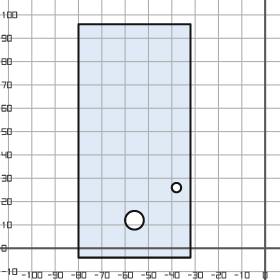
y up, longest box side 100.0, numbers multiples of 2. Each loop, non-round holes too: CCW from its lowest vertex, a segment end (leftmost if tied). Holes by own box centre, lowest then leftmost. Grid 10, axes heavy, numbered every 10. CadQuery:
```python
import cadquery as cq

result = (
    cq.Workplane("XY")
    .moveTo(-80.0, -4.0)
    .lineTo(-32.0, -4.0)
    .lineTo(-32.0, 96.0)
    .lineTo(-80.0, 96.0)
    .close()
    .moveTo(-56.0, 12.0)
    .circle(4.0)
    .moveTo(-38.0, 26.0)
    .circle(2.0)
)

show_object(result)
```